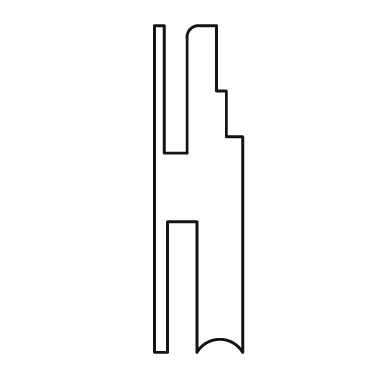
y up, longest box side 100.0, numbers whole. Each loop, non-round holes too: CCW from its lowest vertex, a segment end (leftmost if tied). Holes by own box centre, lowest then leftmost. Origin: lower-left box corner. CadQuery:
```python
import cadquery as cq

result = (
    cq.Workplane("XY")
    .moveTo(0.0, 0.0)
    .lineTo(4.0, 0.0)
    .lineTo(4.0, 40.0)
    .lineTo(13.0, 40.0)
    .lineTo(13.0, 0.0)
    .threePointArc((20.0, 4.0), (27.0, 0.0))
    .lineTo(27.0, 66.0)
    .lineTo(22.0, 66.0)
    .lineTo(22.0, 80.0)
    .lineTo(19.0, 80.0)
    .lineTo(19.0, 100.0)
    .lineTo(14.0, 100.0)
    .threePointArc((11.0, 99.0), (10.0, 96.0))
    .lineTo(10.0, 61.0)
    .lineTo(3.0, 61.0)
    .lineTo(3.0, 100.0)
    .lineTo(0.0, 100.0)
    .close()
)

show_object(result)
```